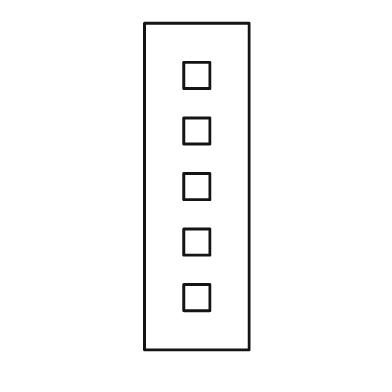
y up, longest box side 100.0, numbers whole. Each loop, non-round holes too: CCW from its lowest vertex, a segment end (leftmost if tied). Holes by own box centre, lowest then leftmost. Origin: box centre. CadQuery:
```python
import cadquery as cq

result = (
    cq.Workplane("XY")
    .moveTo(-16.0, -50.0)
    .lineTo(16.0, -50.0)
    .lineTo(16.0, 50.0)
    .lineTo(-16.0, 50.0)
    .close()
    .moveTo(-4.0, -38.0)
    .lineTo(4.0, -38.0)
    .lineTo(4.0, -30.0)
    .lineTo(-4.0, -30.0)
    .close()
    .moveTo(-4.0, -21.0)
    .lineTo(4.0, -21.0)
    .lineTo(4.0, -13.0)
    .lineTo(-4.0, -13.0)
    .close()
    .moveTo(-4.0, -4.0)
    .lineTo(4.0, -4.0)
    .lineTo(4.0, 4.0)
    .lineTo(-4.0, 4.0)
    .close()
    .moveTo(-4.0, 13.0)
    .lineTo(4.0, 13.0)
    .lineTo(4.0, 21.0)
    .lineTo(-4.0, 21.0)
    .close()
    .moveTo(-4.0, 30.0)
    .lineTo(4.0, 30.0)
    .lineTo(4.0, 38.0)
    .lineTo(-4.0, 38.0)
    .close()
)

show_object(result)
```